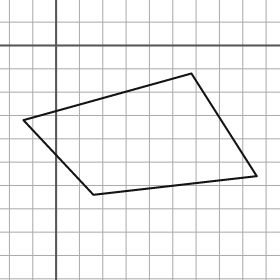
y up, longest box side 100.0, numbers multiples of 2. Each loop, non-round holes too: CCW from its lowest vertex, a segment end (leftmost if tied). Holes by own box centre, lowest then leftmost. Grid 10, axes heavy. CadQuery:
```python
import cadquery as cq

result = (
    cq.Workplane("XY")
    .moveTo(16.0, -64.0)
    .lineTo(86.0, -56.0)
    .lineTo(58.0, -12.0)
    .lineTo(-14.0, -32.0)
    .close()
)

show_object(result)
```